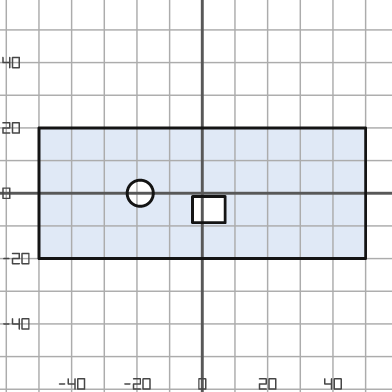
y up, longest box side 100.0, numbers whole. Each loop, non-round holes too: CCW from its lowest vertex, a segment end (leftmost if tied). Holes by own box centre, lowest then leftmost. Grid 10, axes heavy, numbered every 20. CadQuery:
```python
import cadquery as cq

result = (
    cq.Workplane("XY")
    .moveTo(-50.0, -20.0)
    .lineTo(50.0, -20.0)
    .lineTo(50.0, 20.0)
    .lineTo(-50.0, 20.0)
    .close()
    .moveTo(-3.0, -9.0)
    .lineTo(7.0, -9.0)
    .lineTo(7.0, -1.0)
    .lineTo(-3.0, -1.0)
    .close()
    .moveTo(-19.0, 0.0)
    .circle(4.0)
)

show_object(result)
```